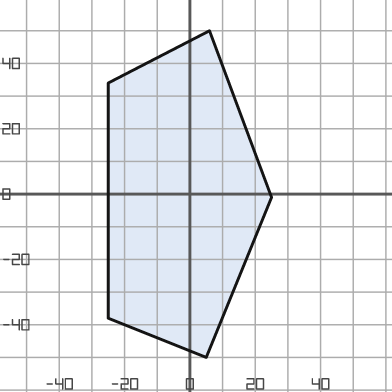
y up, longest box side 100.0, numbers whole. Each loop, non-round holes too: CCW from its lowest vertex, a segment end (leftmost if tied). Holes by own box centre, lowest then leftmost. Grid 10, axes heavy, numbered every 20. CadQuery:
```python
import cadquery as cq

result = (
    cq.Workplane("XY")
    .moveTo(5.0, -50.0)
    .lineTo(25.0, -1.0)
    .lineTo(6.0, 50.0)
    .lineTo(-25.0, 34.0)
    .lineTo(-25.0, -38.0)
    .close()
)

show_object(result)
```